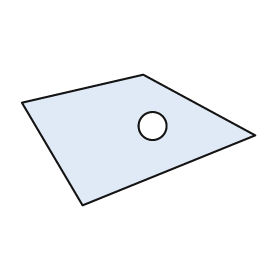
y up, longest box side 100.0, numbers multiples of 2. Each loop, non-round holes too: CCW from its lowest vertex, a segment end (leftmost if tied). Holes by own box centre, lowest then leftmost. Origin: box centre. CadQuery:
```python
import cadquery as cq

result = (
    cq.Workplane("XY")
    .moveTo(-24.0, -28.0)
    .lineTo(50.0, 2.0)
    .lineTo(2.0, 28.0)
    .lineTo(-50.0, 16.0)
    .close()
    .moveTo(6.0, 6.0)
    .circle(6.0)
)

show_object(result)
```